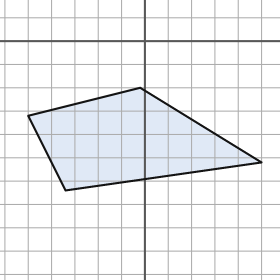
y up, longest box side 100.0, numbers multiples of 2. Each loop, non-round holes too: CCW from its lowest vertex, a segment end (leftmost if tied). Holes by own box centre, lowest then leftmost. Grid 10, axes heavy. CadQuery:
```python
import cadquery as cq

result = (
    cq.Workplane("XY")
    .moveTo(-34.0, -64.0)
    .lineTo(50.0, -52.0)
    .lineTo(-2.0, -20.0)
    .lineTo(-50.0, -32.0)
    .close()
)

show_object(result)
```